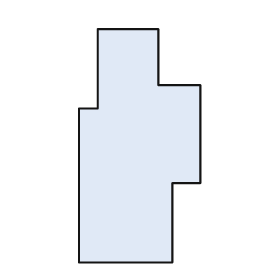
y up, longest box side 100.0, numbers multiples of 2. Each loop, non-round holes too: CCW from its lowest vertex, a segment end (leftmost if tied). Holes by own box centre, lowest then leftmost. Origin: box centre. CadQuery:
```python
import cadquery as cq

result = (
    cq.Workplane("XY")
    .moveTo(-26.0, -50.0)
    .lineTo(14.0, -50.0)
    .lineTo(14.0, -16.0)
    .lineTo(26.0, -16.0)
    .lineTo(26.0, 26.0)
    .lineTo(8.0, 26.0)
    .lineTo(8.0, 50.0)
    .lineTo(-18.0, 50.0)
    .lineTo(-18.0, 16.0)
    .lineTo(-26.0, 16.0)
    .close()
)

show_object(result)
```